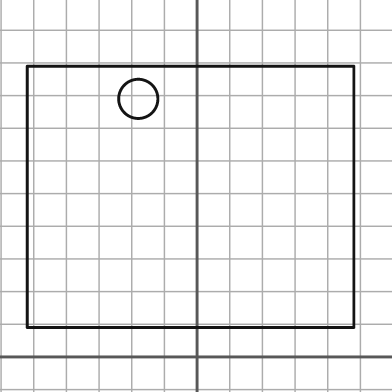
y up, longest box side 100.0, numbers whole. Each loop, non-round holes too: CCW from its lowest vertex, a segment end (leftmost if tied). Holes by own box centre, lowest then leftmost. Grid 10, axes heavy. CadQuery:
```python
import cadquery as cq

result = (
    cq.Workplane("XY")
    .moveTo(-52.0, 9.0)
    .lineTo(48.0, 9.0)
    .lineTo(48.0, 89.0)
    .lineTo(-52.0, 89.0)
    .close()
    .moveTo(-18.0, 79.0)
    .circle(6.0)
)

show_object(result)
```